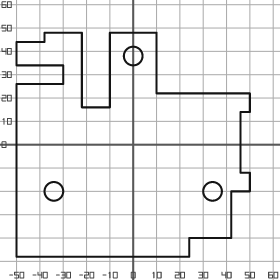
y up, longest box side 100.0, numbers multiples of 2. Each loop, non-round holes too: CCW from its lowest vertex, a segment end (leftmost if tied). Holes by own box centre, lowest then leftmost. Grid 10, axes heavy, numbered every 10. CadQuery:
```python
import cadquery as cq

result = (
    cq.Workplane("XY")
    .moveTo(-50.0, -48.0)
    .lineTo(24.0, -48.0)
    .lineTo(24.0, -40.0)
    .lineTo(42.0, -40.0)
    .lineTo(42.0, -20.0)
    .lineTo(50.0, -20.0)
    .lineTo(50.0, -12.0)
    .lineTo(46.0, -12.0)
    .lineTo(46.0, 14.0)
    .lineTo(50.0, 14.0)
    .lineTo(50.0, 22.0)
    .lineTo(10.0, 22.0)
    .lineTo(10.0, 48.0)
    .lineTo(-10.0, 48.0)
    .lineTo(-10.0, 16.0)
    .lineTo(-22.0, 16.0)
    .lineTo(-22.0, 48.0)
    .lineTo(-38.0, 48.0)
    .lineTo(-38.0, 44.0)
    .lineTo(-50.0, 44.0)
    .lineTo(-50.0, 34.0)
    .lineTo(-30.0, 34.0)
    .lineTo(-30.0, 26.0)
    .lineTo(-50.0, 26.0)
    .close()
    .moveTo(-34.0, -20.0)
    .circle(4.0)
    .moveTo(34.0, -20.0)
    .circle(4.0)
    .moveTo(0.0, 38.0)
    .circle(4.0)
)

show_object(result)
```